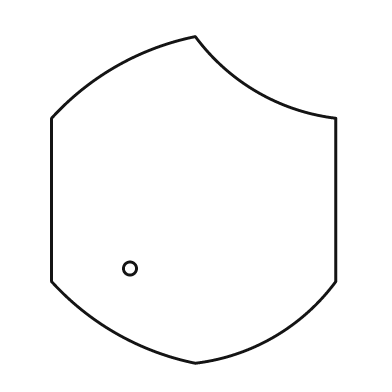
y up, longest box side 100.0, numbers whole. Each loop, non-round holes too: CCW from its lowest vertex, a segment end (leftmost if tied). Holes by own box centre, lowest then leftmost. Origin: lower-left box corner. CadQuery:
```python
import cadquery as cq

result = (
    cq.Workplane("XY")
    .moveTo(44.0, 0.0)
    .threePointArc((68.0, 8.0), (87.0, 25.0))
    .lineTo(87.0, 75.0)
    .threePointArc((63.0, 83.0), (44.0, 100.0))
    .threePointArc((20.0, 91.0), (0.0, 75.0))
    .lineTo(0.0, 25.0)
    .threePointArc((20.0, 9.0), (44.0, 0.0))
    .close()
    .moveTo(24.0, 29.0)
    .circle(2.0)
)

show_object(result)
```